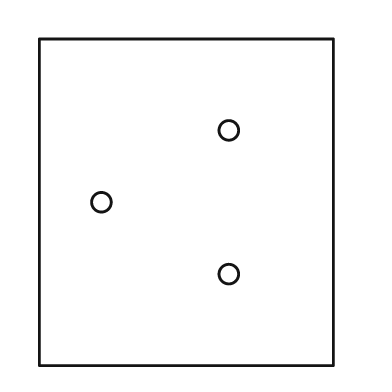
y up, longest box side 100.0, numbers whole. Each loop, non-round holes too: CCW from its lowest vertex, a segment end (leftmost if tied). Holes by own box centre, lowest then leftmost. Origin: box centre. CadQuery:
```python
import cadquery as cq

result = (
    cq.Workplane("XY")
    .moveTo(-45.0, -50.0)
    .lineTo(45.0, -50.0)
    .lineTo(45.0, 50.0)
    .lineTo(-45.0, 50.0)
    .close()
    .moveTo(13.0, -22.0)
    .circle(3.0)
    .moveTo(-26.0, 0.0)
    .circle(3.0)
    .moveTo(13.0, 22.0)
    .circle(3.0)
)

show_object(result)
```